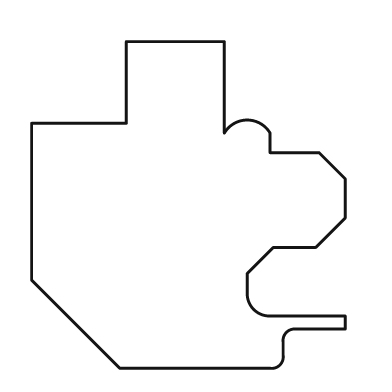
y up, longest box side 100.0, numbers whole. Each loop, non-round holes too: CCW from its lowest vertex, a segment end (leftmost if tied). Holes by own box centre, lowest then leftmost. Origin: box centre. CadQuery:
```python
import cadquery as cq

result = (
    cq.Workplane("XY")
    .moveTo(-21.0, -50.0)
    .lineTo(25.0, -50.0)
    .threePointArc((28.0, -49.0), (29.0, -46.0))
    .lineTo(29.0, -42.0)
    .threePointArc((30.0, -39.0), (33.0, -38.0))
    .lineTo(48.0, -38.0)
    .lineTo(48.0, -34.0)
    .lineTo(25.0, -34.0)
    .threePointArc((20.0, -32.0), (18.0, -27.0))
    .lineTo(18.0, -21.0)
    .lineTo(26.0, -13.0)
    .lineTo(39.0, -13.0)
    .lineTo(48.0, -4.0)
    .lineTo(48.0, 8.0)
    .lineTo(40.0, 16.0)
    .lineTo(25.0, 16.0)
    .lineTo(25.0, 22.0)
    .threePointArc((18.0, 26.0), (11.0, 22.0))
    .lineTo(11.0, 50.0)
    .lineTo(-19.0, 50.0)
    .lineTo(-19.0, 25.0)
    .lineTo(-48.0, 25.0)
    .lineTo(-48.0, -23.0)
    .close()
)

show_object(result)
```